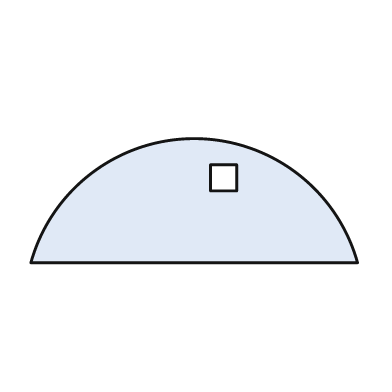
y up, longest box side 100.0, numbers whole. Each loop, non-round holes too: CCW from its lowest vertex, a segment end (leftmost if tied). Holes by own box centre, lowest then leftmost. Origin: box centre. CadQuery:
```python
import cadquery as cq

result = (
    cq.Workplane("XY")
    .moveTo(-50.0, -19.0)
    .lineTo(50.0, -19.0)
    .threePointArc((0.0, 19.0), (-50.0, -19.0))
    .close()
    .moveTo(5.0, 3.0)
    .lineTo(13.0, 3.0)
    .lineTo(13.0, 11.0)
    .lineTo(5.0, 11.0)
    .close()
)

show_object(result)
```